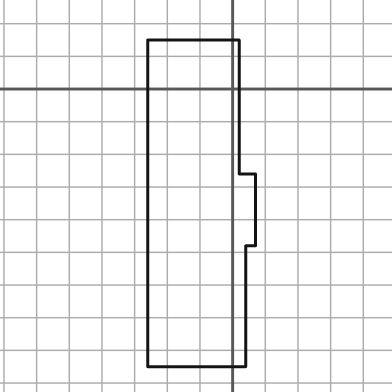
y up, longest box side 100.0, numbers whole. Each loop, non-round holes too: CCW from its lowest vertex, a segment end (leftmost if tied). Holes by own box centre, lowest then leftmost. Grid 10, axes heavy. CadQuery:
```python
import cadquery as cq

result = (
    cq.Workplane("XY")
    .moveTo(-26.0, -85.0)
    .lineTo(4.0, -85.0)
    .lineTo(4.0, -48.0)
    .lineTo(7.0, -48.0)
    .lineTo(7.0, -26.0)
    .lineTo(2.0, -26.0)
    .lineTo(2.0, 15.0)
    .lineTo(-26.0, 15.0)
    .close()
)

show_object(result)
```